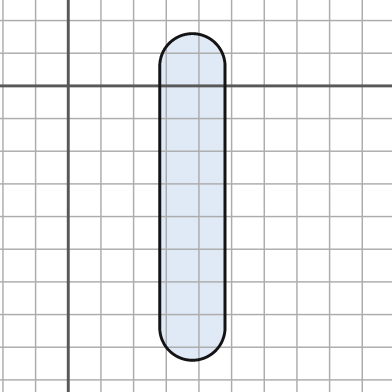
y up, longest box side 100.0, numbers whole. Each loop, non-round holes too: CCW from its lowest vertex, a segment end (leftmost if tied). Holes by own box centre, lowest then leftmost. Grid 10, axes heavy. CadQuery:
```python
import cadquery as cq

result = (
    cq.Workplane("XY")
    .moveTo(28.0, -74.0)
    .threePointArc((38.0, -84.0), (48.0, -74.0))
    .lineTo(48.0, 6.0)
    .threePointArc((38.0, 16.0), (28.0, 6.0))
    .close()
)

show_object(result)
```